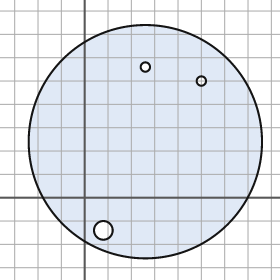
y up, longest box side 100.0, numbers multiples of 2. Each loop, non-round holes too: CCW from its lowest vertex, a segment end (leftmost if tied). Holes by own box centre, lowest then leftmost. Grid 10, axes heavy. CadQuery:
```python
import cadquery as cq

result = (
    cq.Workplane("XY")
    .moveTo(26.0, 24.0)
    .circle(50.0)
    .moveTo(8.0, -14.0)
    .circle(4.0)
    .moveTo(50.0, 50.0)
    .circle(2.0)
    .moveTo(26.0, 56.0)
    .circle(2.0)
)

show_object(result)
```